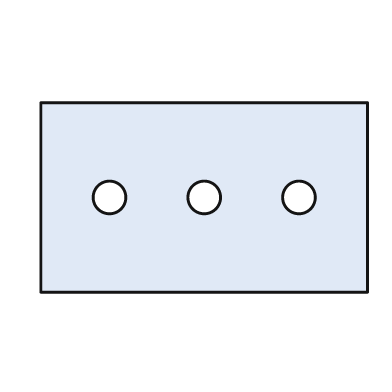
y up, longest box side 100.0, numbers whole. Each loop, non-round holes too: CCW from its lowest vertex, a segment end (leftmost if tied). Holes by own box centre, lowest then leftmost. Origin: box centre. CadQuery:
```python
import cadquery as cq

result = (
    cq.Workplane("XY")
    .moveTo(-50.0, -29.0)
    .lineTo(50.0, -29.0)
    .lineTo(50.0, 29.0)
    .lineTo(-50.0, 29.0)
    .close()
    .moveTo(-29.0, 0.0)
    .circle(5.0)
    .moveTo(0.0, 0.0)
    .circle(5.0)
    .moveTo(29.0, 0.0)
    .circle(5.0)
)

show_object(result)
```